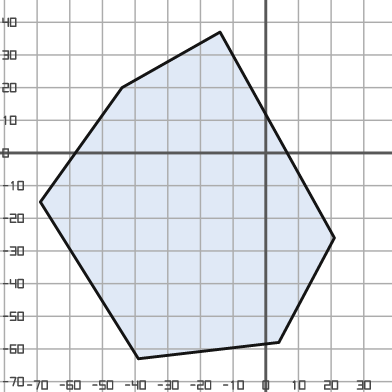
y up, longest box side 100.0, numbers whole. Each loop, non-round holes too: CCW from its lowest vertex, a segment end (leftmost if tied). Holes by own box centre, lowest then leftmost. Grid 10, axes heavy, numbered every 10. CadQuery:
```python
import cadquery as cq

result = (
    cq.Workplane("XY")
    .moveTo(-39.0, -63.0)
    .lineTo(4.0, -58.0)
    .lineTo(21.0, -26.0)
    .lineTo(-14.0, 37.0)
    .lineTo(-44.0, 20.0)
    .lineTo(-69.0, -15.0)
    .close()
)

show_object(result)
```